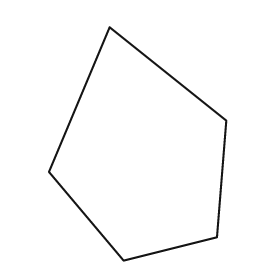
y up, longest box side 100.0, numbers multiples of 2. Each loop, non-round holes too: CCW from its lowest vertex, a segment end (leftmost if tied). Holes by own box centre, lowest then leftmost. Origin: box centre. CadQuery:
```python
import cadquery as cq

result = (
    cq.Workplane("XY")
    .moveTo(-6.0, -50.0)
    .lineTo(34.0, -40.0)
    .lineTo(38.0, 10.0)
    .lineTo(-12.0, 50.0)
    .lineTo(-38.0, -12.0)
    .close()
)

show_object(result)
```